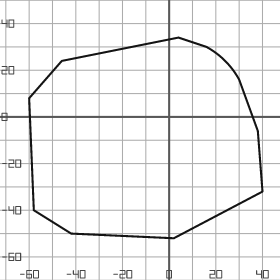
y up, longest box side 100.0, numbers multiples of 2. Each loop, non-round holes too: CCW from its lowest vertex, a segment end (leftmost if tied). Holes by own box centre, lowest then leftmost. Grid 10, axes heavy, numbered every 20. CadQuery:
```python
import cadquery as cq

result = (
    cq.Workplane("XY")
    .moveTo(2.0, -52.0)
    .lineTo(40.0, -32.0)
    .lineTo(38.0, -6.0)
    .lineTo(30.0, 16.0)
    .threePointArc((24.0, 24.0), (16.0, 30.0))
    .lineTo(4.0, 34.0)
    .lineTo(-46.0, 24.0)
    .lineTo(-60.0, 8.0)
    .lineTo(-58.0, -40.0)
    .lineTo(-42.0, -50.0)
    .close()
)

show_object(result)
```